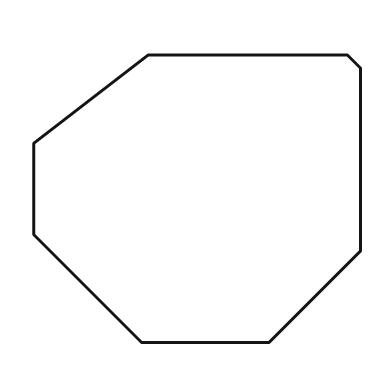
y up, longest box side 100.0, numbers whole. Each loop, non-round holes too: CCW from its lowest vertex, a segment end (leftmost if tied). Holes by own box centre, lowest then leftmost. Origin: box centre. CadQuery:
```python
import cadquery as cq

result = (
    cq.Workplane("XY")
    .moveTo(-17.0, -44.0)
    .lineTo(22.0, -44.0)
    .lineTo(50.0, -16.0)
    .lineTo(50.0, 40.0)
    .lineTo(46.0, 44.0)
    .lineTo(-15.0, 44.0)
    .lineTo(-50.0, 17.0)
    .lineTo(-50.0, -11.0)
    .close()
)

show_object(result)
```